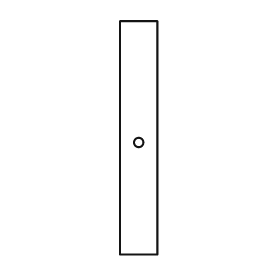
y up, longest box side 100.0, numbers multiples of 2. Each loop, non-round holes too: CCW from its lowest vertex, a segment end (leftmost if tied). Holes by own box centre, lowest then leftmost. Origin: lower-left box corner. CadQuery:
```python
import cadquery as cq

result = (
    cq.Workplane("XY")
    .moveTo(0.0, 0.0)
    .lineTo(16.0, 0.0)
    .lineTo(16.0, 100.0)
    .lineTo(0.0, 100.0)
    .close()
    .moveTo(8.0, 48.0)
    .circle(2.0)
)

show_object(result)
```